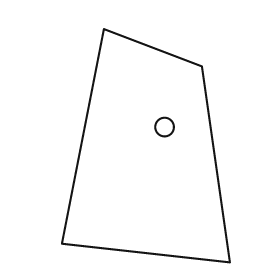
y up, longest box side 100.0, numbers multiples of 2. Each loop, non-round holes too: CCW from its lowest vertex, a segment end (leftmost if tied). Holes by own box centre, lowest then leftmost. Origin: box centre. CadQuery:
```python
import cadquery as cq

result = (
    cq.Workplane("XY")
    .moveTo(36.0, -50.0)
    .lineTo(24.0, 34.0)
    .lineTo(-18.0, 50.0)
    .lineTo(-36.0, -42.0)
    .close()
    .moveTo(8.0, 8.0)
    .circle(4.0)
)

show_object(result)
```